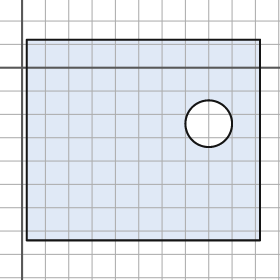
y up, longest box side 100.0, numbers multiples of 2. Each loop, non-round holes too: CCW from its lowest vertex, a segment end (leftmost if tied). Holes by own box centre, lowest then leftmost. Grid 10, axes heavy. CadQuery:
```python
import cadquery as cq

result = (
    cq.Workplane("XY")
    .moveTo(2.0, -74.0)
    .lineTo(102.0, -74.0)
    .lineTo(102.0, 12.0)
    .lineTo(2.0, 12.0)
    .close()
    .moveTo(80.0, -24.0)
    .circle(10.0)
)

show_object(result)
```